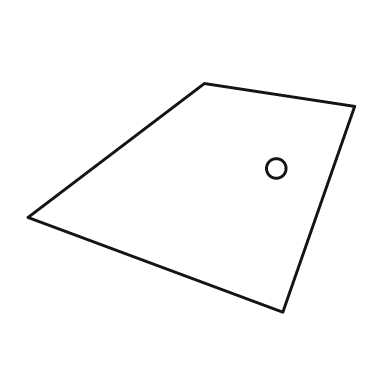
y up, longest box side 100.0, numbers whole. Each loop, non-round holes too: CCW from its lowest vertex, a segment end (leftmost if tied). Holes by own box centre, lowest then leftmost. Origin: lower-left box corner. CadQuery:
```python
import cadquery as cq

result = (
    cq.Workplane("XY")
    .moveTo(78.0, 0.0)
    .lineTo(100.0, 63.0)
    .lineTo(54.0, 70.0)
    .lineTo(0.0, 29.0)
    .close()
    .moveTo(76.0, 44.0)
    .circle(3.0)
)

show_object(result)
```